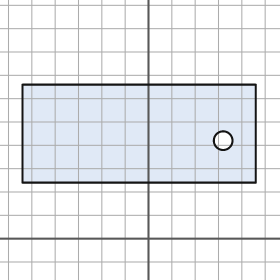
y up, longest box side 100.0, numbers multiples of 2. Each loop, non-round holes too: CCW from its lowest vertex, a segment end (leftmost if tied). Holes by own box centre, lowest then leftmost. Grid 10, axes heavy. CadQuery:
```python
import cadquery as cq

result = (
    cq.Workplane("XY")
    .moveTo(-54.0, 24.0)
    .lineTo(46.0, 24.0)
    .lineTo(46.0, 66.0)
    .lineTo(-54.0, 66.0)
    .close()
    .moveTo(32.0, 42.0)
    .circle(4.0)
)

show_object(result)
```